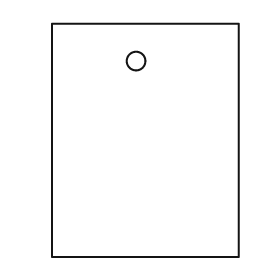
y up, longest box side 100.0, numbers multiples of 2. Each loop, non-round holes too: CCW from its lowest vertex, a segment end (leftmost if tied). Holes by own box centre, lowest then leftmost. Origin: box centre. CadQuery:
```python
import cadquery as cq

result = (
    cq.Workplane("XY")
    .moveTo(-40.0, -50.0)
    .lineTo(40.0, -50.0)
    .lineTo(40.0, 50.0)
    .lineTo(-40.0, 50.0)
    .close()
    .moveTo(-4.0, 34.0)
    .circle(4.0)
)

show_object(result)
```